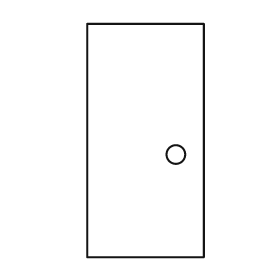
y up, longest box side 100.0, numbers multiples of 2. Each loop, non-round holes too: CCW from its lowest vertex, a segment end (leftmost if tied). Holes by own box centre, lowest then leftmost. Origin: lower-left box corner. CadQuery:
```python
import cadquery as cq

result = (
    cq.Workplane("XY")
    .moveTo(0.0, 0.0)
    .lineTo(50.0, 0.0)
    .lineTo(50.0, 100.0)
    .lineTo(0.0, 100.0)
    .close()
    .moveTo(38.0, 44.0)
    .circle(4.0)
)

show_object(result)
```